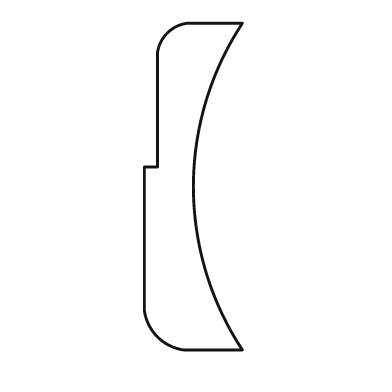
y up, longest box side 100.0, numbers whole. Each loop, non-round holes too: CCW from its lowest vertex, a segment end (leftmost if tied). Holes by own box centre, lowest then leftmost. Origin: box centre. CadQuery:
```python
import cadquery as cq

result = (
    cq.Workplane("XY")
    .moveTo(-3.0, -50.0)
    .lineTo(15.0, -50.0)
    .threePointArc((0.0, 0.0), (15.0, 50.0))
    .lineTo(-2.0, 50.0)
    .threePointArc((-8.0, 47.0), (-11.0, 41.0))
    .lineTo(-11.0, 6.0)
    .lineTo(-15.0, 6.0)
    .lineTo(-15.0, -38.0)
    .threePointArc((-11.0, -46.0), (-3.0, -50.0))
    .close()
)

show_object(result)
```